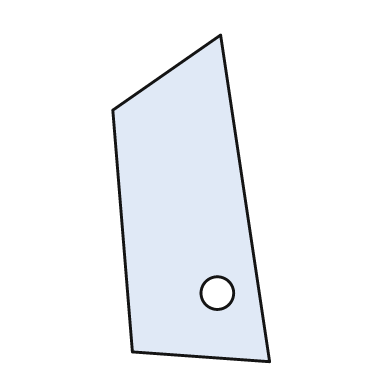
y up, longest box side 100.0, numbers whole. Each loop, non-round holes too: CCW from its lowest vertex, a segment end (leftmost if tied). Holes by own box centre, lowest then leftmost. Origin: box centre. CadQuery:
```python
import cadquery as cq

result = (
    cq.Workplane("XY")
    .moveTo(24.0, -50.0)
    .lineTo(9.0, 50.0)
    .lineTo(-24.0, 27.0)
    .lineTo(-18.0, -47.0)
    .close()
    .moveTo(8.0, -29.0)
    .circle(5.0)
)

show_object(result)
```